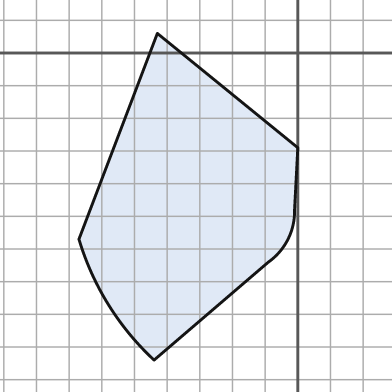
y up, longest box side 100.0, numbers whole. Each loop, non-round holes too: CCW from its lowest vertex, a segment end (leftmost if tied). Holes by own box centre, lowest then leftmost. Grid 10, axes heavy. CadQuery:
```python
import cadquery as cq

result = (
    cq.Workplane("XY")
    .moveTo(-44.0, -94.0)
    .lineTo(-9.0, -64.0)
    .threePointArc((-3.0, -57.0), (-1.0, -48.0))
    .lineTo(0.0, -29.0)
    .lineTo(-43.0, 6.0)
    .lineTo(-67.0, -57.0)
    .threePointArc((-58.0, -77.0), (-44.0, -94.0))
    .close()
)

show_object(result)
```